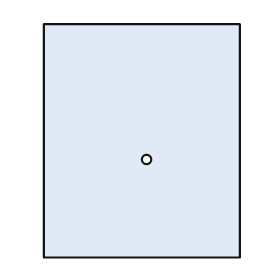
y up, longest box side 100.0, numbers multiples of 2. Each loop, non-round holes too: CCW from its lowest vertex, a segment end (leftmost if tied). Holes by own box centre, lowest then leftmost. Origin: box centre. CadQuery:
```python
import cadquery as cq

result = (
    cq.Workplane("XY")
    .moveTo(-42.0, -50.0)
    .lineTo(42.0, -50.0)
    .lineTo(42.0, 50.0)
    .lineTo(-42.0, 50.0)
    .close()
    .moveTo(2.0, -8.0)
    .circle(2.0)
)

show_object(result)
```